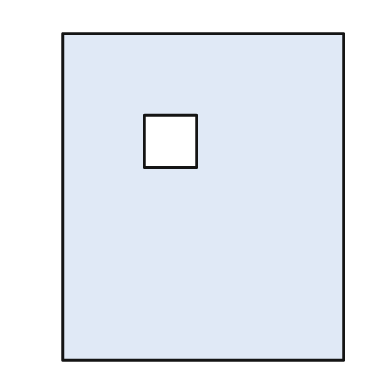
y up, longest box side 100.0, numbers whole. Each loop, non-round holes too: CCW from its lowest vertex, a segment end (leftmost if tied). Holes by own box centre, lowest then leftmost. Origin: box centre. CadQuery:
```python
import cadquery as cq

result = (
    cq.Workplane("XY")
    .moveTo(-43.0, -50.0)
    .lineTo(43.0, -50.0)
    .lineTo(43.0, 50.0)
    .lineTo(-43.0, 50.0)
    .close()
    .moveTo(-18.0, 9.0)
    .lineTo(-2.0, 9.0)
    .lineTo(-2.0, 25.0)
    .lineTo(-18.0, 25.0)
    .close()
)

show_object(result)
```